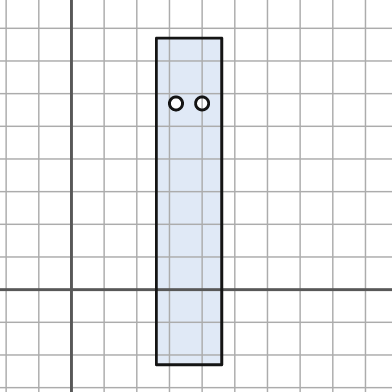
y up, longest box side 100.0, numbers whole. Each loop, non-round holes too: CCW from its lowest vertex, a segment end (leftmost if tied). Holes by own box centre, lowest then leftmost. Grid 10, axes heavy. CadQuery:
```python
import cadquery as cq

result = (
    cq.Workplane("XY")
    .moveTo(26.0, -23.0)
    .lineTo(46.0, -23.0)
    .lineTo(46.0, 77.0)
    .lineTo(26.0, 77.0)
    .close()
    .moveTo(32.0, 57.0)
    .circle(2.0)
    .moveTo(40.0, 57.0)
    .circle(2.0)
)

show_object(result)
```